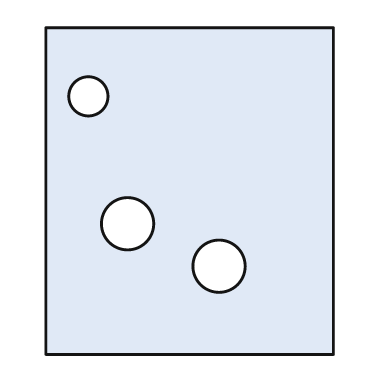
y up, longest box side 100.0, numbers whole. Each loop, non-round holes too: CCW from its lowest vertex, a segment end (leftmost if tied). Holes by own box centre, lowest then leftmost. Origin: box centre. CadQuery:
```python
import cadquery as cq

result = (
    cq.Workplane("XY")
    .moveTo(-44.0, -50.0)
    .lineTo(44.0, -50.0)
    .lineTo(44.0, 50.0)
    .lineTo(-44.0, 50.0)
    .close()
    .moveTo(9.0, -23.0)
    .circle(8.0)
    .moveTo(-19.0, -10.0)
    .circle(8.0)
    .moveTo(-31.0, 29.0)
    .circle(6.0)
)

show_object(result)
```